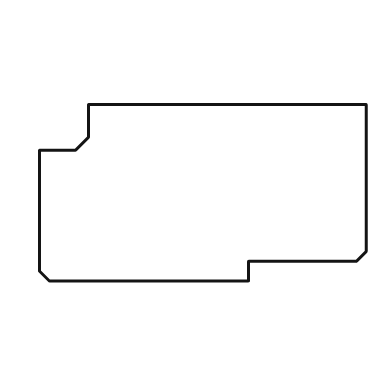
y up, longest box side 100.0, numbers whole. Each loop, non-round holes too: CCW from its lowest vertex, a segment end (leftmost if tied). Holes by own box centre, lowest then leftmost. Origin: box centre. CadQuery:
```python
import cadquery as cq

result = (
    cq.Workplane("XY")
    .moveTo(-47.0, -27.0)
    .lineTo(14.0, -27.0)
    .lineTo(14.0, -21.0)
    .lineTo(47.0, -21.0)
    .lineTo(50.0, -18.0)
    .lineTo(50.0, 27.0)
    .lineTo(-35.0, 27.0)
    .lineTo(-35.0, 17.0)
    .lineTo(-39.0, 13.0)
    .lineTo(-50.0, 13.0)
    .lineTo(-50.0, -24.0)
    .close()
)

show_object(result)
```